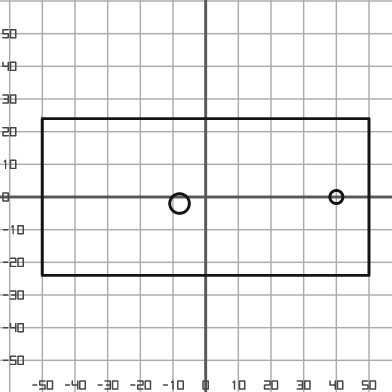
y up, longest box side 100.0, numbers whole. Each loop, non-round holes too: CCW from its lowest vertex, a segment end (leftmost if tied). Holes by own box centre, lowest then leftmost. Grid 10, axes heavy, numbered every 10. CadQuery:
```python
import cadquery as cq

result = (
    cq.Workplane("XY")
    .moveTo(-50.0, -24.0)
    .lineTo(50.0, -24.0)
    .lineTo(50.0, 24.0)
    .lineTo(-50.0, 24.0)
    .close()
    .moveTo(-8.0, -2.0)
    .circle(3.0)
    .moveTo(40.0, 0.0)
    .circle(2.0)
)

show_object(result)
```